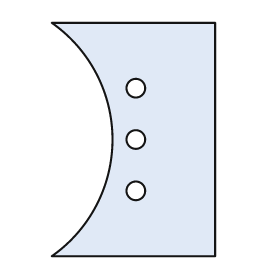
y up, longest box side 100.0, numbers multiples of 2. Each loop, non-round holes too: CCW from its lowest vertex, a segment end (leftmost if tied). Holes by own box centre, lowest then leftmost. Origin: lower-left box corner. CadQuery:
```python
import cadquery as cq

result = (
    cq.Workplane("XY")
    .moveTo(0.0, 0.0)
    .lineTo(70.0, 0.0)
    .lineTo(70.0, 100.0)
    .lineTo(0.0, 100.0)
    .threePointArc((26.0, 50.0), (0.0, 0.0))
    .close()
    .moveTo(36.0, 28.0)
    .circle(4.0)
    .moveTo(36.0, 50.0)
    .circle(4.0)
    .moveTo(36.0, 72.0)
    .circle(4.0)
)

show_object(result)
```